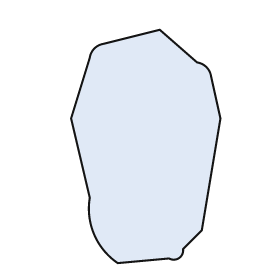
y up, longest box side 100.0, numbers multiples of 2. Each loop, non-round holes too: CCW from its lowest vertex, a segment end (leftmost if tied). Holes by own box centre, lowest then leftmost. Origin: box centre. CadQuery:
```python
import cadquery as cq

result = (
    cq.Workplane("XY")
    .moveTo(-12.0, -50.0)
    .lineTo(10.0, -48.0)
    .threePointArc((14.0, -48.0), (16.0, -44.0))
    .lineTo(24.0, -36.0)
    .lineTo(32.0, 12.0)
    .lineTo(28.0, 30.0)
    .threePointArc((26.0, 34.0), (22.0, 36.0))
    .lineTo(6.0, 50.0)
    .lineTo(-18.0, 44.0)
    .threePointArc((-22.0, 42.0), (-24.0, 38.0))
    .lineTo(-32.0, 12.0)
    .lineTo(-24.0, -22.0)
    .threePointArc((-22.0, -38.0), (-12.0, -50.0))
    .close()
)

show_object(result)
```